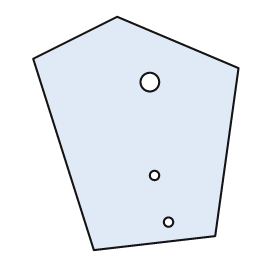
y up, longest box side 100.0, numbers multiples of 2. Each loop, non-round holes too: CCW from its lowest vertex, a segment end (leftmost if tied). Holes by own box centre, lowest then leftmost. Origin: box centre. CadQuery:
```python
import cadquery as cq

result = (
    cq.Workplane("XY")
    .moveTo(-18.0, -50.0)
    .lineTo(34.0, -44.0)
    .lineTo(44.0, 28.0)
    .lineTo(-8.0, 50.0)
    .lineTo(-44.0, 32.0)
    .close()
    .moveTo(14.0, -38.0)
    .circle(2.0)
    .moveTo(8.0, -18.0)
    .circle(2.0)
    .moveTo(6.0, 22.0)
    .circle(4.0)
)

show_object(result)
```